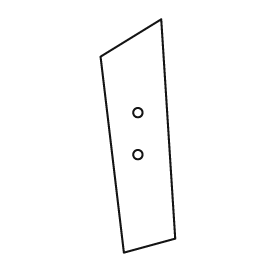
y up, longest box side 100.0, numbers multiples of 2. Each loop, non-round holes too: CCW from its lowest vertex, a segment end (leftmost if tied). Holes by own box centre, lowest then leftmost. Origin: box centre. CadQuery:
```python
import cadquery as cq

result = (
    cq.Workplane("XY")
    .moveTo(-6.0, -50.0)
    .lineTo(16.0, -44.0)
    .lineTo(10.0, 50.0)
    .lineTo(-16.0, 34.0)
    .close()
    .moveTo(0.0, -8.0)
    .circle(2.0)
    .moveTo(0.0, 10.0)
    .circle(2.0)
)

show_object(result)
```